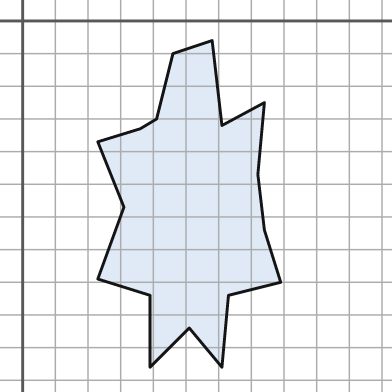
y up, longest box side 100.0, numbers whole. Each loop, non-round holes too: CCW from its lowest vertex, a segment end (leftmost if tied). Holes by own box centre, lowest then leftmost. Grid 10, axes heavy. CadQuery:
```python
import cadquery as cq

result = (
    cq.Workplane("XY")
    .moveTo(39.0, -106.0)
    .lineTo(51.0, -94.0)
    .lineTo(61.0, -106.0)
    .lineTo(63.0, -84.0)
    .lineTo(79.0, -80.0)
    .lineTo(74.0, -64.0)
    .lineTo(72.0, -47.0)
    .lineTo(74.0, -25.0)
    .lineTo(61.0, -32.0)
    .lineTo(58.0, -6.0)
    .lineTo(46.0, -10.0)
    .lineTo(41.0, -30.0)
    .lineTo(36.0, -33.0)
    .lineTo(23.0, -37.0)
    .lineTo(31.0, -57.0)
    .lineTo(23.0, -79.0)
    .lineTo(39.0, -84.0)
    .close()
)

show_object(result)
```